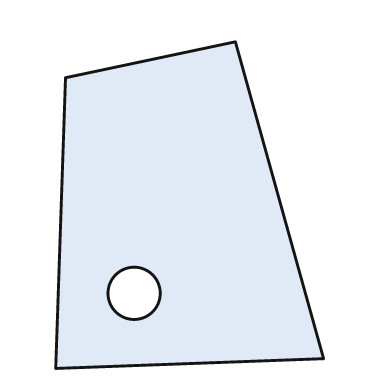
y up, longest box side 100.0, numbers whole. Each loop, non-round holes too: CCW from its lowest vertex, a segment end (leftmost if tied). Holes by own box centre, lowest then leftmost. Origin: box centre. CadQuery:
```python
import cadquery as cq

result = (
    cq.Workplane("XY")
    .moveTo(-41.0, -50.0)
    .lineTo(41.0, -47.0)
    .lineTo(14.0, 50.0)
    .lineTo(-38.0, 39.0)
    .close()
    .moveTo(-17.0, -27.0)
    .circle(8.0)
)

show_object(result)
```